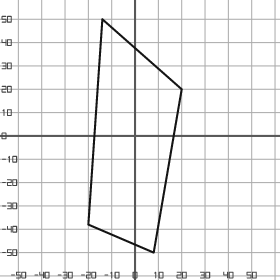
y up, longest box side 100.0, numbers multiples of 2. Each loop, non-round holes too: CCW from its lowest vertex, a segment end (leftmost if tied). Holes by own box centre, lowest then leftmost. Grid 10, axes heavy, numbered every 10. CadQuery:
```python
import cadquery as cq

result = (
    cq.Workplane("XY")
    .moveTo(8.0, -50.0)
    .lineTo(20.0, 20.0)
    .lineTo(-14.0, 50.0)
    .lineTo(-20.0, -38.0)
    .close()
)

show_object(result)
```